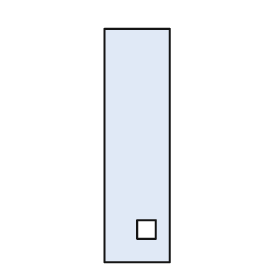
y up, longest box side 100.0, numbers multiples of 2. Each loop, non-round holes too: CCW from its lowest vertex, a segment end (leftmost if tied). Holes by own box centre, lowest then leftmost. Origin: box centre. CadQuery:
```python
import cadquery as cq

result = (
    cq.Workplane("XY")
    .moveTo(-14.0, -50.0)
    .lineTo(14.0, -50.0)
    .lineTo(14.0, 50.0)
    .lineTo(-14.0, 50.0)
    .close()
    .moveTo(0.0, -40.0)
    .lineTo(8.0, -40.0)
    .lineTo(8.0, -32.0)
    .lineTo(0.0, -32.0)
    .close()
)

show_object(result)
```